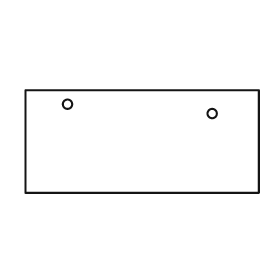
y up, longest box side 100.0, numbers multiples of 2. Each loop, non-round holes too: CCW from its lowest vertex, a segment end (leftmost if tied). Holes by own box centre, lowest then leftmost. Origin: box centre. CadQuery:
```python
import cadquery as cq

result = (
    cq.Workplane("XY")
    .moveTo(-50.0, -22.0)
    .lineTo(50.0, -22.0)
    .lineTo(50.0, 22.0)
    .lineTo(-50.0, 22.0)
    .close()
    .moveTo(30.0, 12.0)
    .circle(2.0)
    .moveTo(-32.0, 16.0)
    .circle(2.0)
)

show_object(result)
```